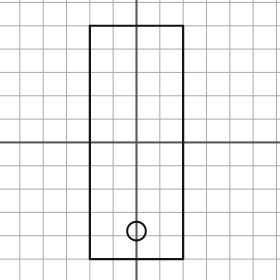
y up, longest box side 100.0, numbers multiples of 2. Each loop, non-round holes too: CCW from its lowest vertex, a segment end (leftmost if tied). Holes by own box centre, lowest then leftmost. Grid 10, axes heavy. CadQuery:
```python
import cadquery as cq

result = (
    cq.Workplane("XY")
    .moveTo(-20.0, -50.0)
    .lineTo(20.0, -50.0)
    .lineTo(20.0, 50.0)
    .lineTo(-20.0, 50.0)
    .close()
    .moveTo(0.0, -38.0)
    .circle(4.0)
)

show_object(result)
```